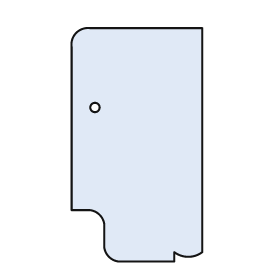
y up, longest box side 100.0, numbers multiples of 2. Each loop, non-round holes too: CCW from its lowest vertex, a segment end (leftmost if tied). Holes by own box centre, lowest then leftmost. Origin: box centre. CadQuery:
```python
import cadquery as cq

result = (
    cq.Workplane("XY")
    .moveTo(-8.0, -50.0)
    .lineTo(16.0, -50.0)
    .lineTo(16.0, -46.0)
    .threePointArc((22.0, -48.0), (28.0, -46.0))
    .lineTo(28.0, 50.0)
    .lineTo(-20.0, 50.0)
    .threePointArc((-26.0, 48.0), (-28.0, 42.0))
    .lineTo(-28.0, -28.0)
    .lineTo(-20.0, -28.0)
    .threePointArc((-16.0, -30.0), (-14.0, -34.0))
    .lineTo(-14.0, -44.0)
    .threePointArc((-12.0, -48.0), (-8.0, -50.0))
    .close()
    .moveTo(-18.0, 16.0)
    .circle(2.0)
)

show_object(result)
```